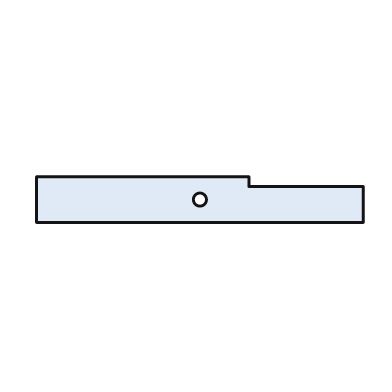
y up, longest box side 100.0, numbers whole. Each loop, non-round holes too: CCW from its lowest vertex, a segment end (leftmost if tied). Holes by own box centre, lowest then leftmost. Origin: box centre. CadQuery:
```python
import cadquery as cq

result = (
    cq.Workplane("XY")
    .moveTo(-50.0, -7.0)
    .lineTo(50.0, -7.0)
    .lineTo(50.0, 4.0)
    .lineTo(15.0, 4.0)
    .lineTo(15.0, 7.0)
    .lineTo(-50.0, 7.0)
    .close()
    .moveTo(0.0, 0.0)
    .circle(2.0)
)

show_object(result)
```